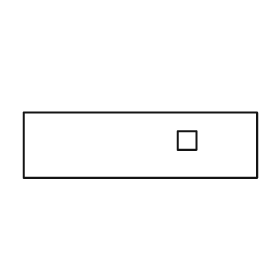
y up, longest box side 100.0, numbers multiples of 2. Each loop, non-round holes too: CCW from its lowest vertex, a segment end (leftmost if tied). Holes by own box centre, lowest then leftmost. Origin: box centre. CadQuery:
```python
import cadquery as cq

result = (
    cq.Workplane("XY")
    .moveTo(-50.0, -14.0)
    .lineTo(50.0, -14.0)
    .lineTo(50.0, 14.0)
    .lineTo(-50.0, 14.0)
    .close()
    .moveTo(16.0, -2.0)
    .lineTo(24.0, -2.0)
    .lineTo(24.0, 6.0)
    .lineTo(16.0, 6.0)
    .close()
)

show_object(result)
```